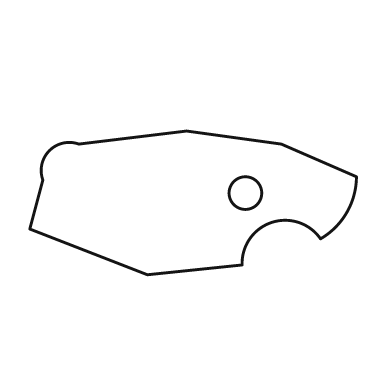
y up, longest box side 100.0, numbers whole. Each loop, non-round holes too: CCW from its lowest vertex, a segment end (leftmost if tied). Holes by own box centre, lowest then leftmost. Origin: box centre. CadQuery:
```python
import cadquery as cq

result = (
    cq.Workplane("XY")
    .moveTo(-14.0, -22.0)
    .lineTo(15.0, -19.0)
    .threePointArc((24.0, -6.0), (39.0, -11.0))
    .threePointArc((47.0, -3.0), (50.0, 8.0))
    .lineTo(27.0, 18.0)
    .lineTo(-2.0, 22.0)
    .lineTo(-35.0, 18.0)
    .threePointArc((-44.0, 16.0), (-46.0, 7.0))
    .lineTo(-50.0, -8.0)
    .close()
    .moveTo(16.0, 3.0)
    .circle(5.0)
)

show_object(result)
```